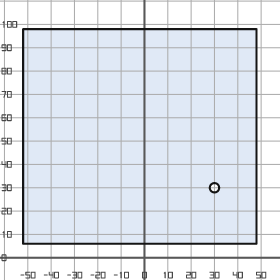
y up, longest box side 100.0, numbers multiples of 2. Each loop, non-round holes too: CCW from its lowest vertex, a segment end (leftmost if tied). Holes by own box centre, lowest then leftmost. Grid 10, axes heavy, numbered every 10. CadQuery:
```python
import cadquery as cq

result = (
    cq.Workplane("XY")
    .moveTo(-52.0, 6.0)
    .lineTo(48.0, 6.0)
    .lineTo(48.0, 98.0)
    .lineTo(-52.0, 98.0)
    .close()
    .moveTo(30.0, 30.0)
    .circle(2.0)
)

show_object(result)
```